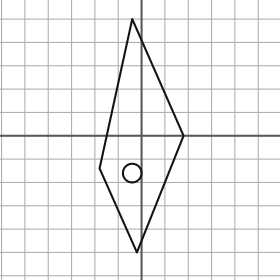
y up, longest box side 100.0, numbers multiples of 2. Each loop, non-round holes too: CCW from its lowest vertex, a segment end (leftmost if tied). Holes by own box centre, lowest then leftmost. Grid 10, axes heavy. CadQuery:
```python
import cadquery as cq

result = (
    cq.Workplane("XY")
    .moveTo(-2.0, -50.0)
    .lineTo(18.0, 0.0)
    .lineTo(-4.0, 50.0)
    .lineTo(-18.0, -14.0)
    .close()
    .moveTo(-4.0, -16.0)
    .circle(4.0)
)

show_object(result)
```